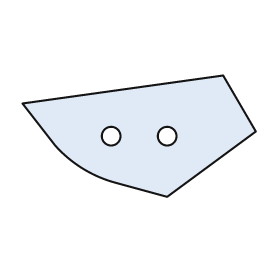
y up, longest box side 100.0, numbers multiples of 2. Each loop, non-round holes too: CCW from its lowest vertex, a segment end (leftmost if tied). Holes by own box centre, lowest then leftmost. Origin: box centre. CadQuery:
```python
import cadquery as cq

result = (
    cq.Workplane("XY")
    .moveTo(12.0, -26.0)
    .lineTo(50.0, 2.0)
    .lineTo(36.0, 26.0)
    .lineTo(-50.0, 14.0)
    .lineTo(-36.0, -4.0)
    .threePointArc((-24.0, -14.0), (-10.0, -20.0))
    .close()
    .moveTo(-12.0, 0.0)
    .circle(4.0)
    .moveTo(12.0, 0.0)
    .circle(4.0)
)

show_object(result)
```